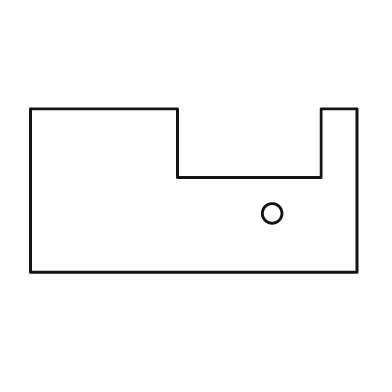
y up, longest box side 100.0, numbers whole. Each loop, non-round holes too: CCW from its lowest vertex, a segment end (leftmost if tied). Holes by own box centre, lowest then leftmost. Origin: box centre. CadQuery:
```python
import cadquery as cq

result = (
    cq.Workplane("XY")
    .moveTo(-50.0, -25.0)
    .lineTo(50.0, -25.0)
    .lineTo(50.0, 25.0)
    .lineTo(39.0, 25.0)
    .lineTo(39.0, 4.0)
    .lineTo(-5.0, 4.0)
    .lineTo(-5.0, 25.0)
    .lineTo(-50.0, 25.0)
    .close()
    .moveTo(24.0, -7.0)
    .circle(3.0)
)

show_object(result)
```